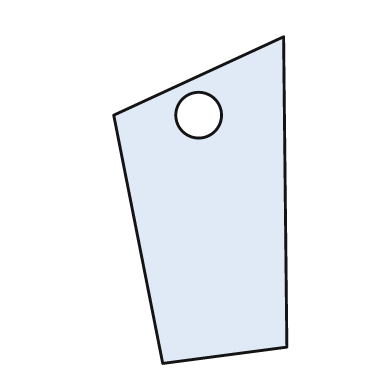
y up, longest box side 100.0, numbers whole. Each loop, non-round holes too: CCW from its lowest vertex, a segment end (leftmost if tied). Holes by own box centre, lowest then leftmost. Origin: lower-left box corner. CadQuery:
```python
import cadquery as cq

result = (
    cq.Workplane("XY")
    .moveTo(15.0, 0.0)
    .lineTo(53.0, 5.0)
    .lineTo(52.0, 100.0)
    .lineTo(0.0, 76.0)
    .close()
    .moveTo(26.0, 76.0)
    .circle(7.0)
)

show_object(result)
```